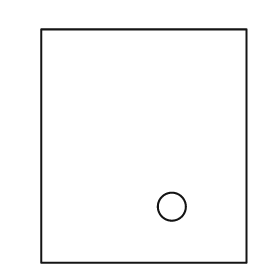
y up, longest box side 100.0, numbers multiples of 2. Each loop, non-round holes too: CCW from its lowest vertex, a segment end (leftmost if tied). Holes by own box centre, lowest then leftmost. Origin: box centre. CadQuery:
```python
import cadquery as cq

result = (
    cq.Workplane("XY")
    .moveTo(-44.0, -50.0)
    .lineTo(44.0, -50.0)
    .lineTo(44.0, 50.0)
    .lineTo(-44.0, 50.0)
    .close()
    .moveTo(12.0, -26.0)
    .circle(6.0)
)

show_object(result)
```